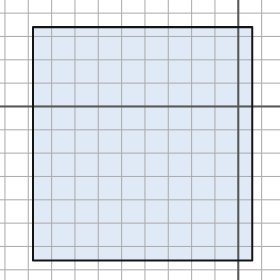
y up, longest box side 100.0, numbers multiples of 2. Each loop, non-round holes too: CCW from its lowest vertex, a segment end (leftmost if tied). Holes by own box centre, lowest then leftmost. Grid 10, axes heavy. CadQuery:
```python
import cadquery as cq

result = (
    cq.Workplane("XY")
    .moveTo(-88.0, -66.0)
    .lineTo(6.0, -66.0)
    .lineTo(6.0, 34.0)
    .lineTo(-88.0, 34.0)
    .close()
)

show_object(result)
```